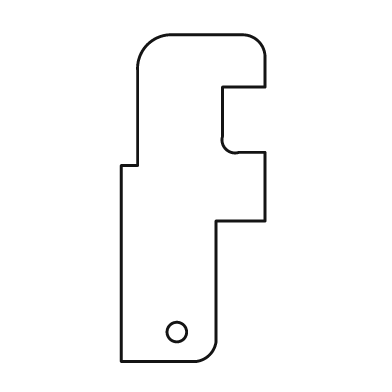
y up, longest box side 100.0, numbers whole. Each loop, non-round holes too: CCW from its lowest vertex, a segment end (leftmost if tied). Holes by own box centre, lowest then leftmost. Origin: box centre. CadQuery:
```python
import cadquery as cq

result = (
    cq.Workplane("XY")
    .moveTo(-22.0, -50.0)
    .lineTo(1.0, -50.0)
    .threePointArc((5.0, -48.0), (7.0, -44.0))
    .lineTo(7.0, -7.0)
    .lineTo(22.0, -7.0)
    .lineTo(22.0, 14.0)
    .lineTo(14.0, 14.0)
    .threePointArc((10.0, 15.0), (9.0, 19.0))
    .lineTo(9.0, 34.0)
    .lineTo(22.0, 34.0)
    .lineTo(22.0, 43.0)
    .threePointArc((20.0, 48.0), (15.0, 50.0))
    .lineTo(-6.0, 50.0)
    .threePointArc((-14.0, 47.0), (-17.0, 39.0))
    .lineTo(-17.0, 10.0)
    .lineTo(-22.0, 10.0)
    .close()
    .moveTo(-5.0, -41.0)
    .circle(3.0)
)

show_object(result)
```